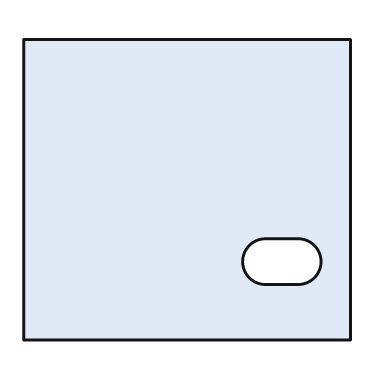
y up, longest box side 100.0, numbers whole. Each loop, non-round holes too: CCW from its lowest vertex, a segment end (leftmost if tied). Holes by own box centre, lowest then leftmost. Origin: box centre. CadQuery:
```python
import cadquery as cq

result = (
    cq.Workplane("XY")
    .moveTo(-50.0, -46.0)
    .lineTo(50.0, -46.0)
    .lineTo(50.0, 46.0)
    .lineTo(-50.0, 46.0)
    .close()
    .moveTo(24.0, -29.0)
    .lineTo(34.0, -29.0)
    .threePointArc((41.0, -22.0), (34.0, -15.0))
    .lineTo(24.0, -15.0)
    .threePointArc((17.0, -22.0), (24.0, -29.0))
    .close()
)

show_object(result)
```